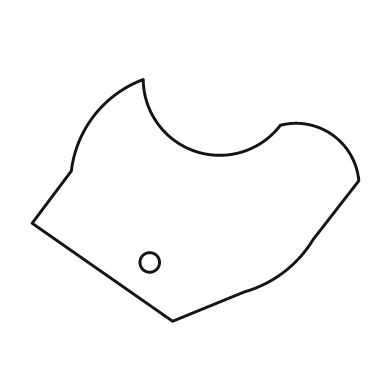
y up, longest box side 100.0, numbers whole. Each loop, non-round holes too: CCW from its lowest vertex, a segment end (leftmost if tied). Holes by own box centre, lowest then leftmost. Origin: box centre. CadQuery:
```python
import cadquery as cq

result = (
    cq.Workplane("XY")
    .moveTo(-7.0, -37.0)
    .lineTo(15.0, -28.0)
    .threePointArc((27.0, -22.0), (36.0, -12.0))
    .lineTo(50.0, 6.0)
    .threePointArc((42.0, 20.0), (26.0, 23.0))
    .threePointArc((0.0, 15.0), (-16.0, 37.0))
    .threePointArc((-31.0, 26.0), (-38.0, 9.0))
    .lineTo(-50.0, -7.0)
    .close()
    .moveTo(-14.0, -19.0)
    .circle(3.0)
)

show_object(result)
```